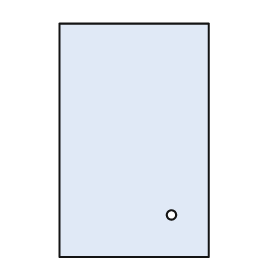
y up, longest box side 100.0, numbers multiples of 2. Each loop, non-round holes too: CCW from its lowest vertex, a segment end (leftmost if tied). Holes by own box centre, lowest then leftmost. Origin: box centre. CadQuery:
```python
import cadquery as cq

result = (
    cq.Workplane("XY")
    .moveTo(-32.0, -50.0)
    .lineTo(32.0, -50.0)
    .lineTo(32.0, 50.0)
    .lineTo(-32.0, 50.0)
    .close()
    .moveTo(16.0, -32.0)
    .circle(2.0)
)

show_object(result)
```